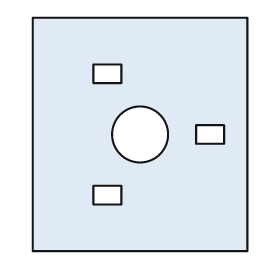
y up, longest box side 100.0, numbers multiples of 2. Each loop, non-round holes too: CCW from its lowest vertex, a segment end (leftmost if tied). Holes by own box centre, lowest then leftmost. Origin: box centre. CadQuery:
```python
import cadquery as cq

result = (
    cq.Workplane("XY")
    .moveTo(-46.0, -50.0)
    .lineTo(46.0, -50.0)
    .lineTo(46.0, 50.0)
    .lineTo(-46.0, 50.0)
    .close()
    .moveTo(-20.0, -30.0)
    .lineTo(-8.0, -30.0)
    .lineTo(-8.0, -22.0)
    .lineTo(-20.0, -22.0)
    .close()
    .moveTo(0.0, 0.0)
    .circle(12.0)
    .moveTo(24.0, -4.0)
    .lineTo(36.0, -4.0)
    .lineTo(36.0, 4.0)
    .lineTo(24.0, 4.0)
    .close()
    .moveTo(-20.0, 22.0)
    .lineTo(-8.0, 22.0)
    .lineTo(-8.0, 30.0)
    .lineTo(-20.0, 30.0)
    .close()
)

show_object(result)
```